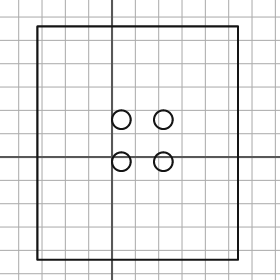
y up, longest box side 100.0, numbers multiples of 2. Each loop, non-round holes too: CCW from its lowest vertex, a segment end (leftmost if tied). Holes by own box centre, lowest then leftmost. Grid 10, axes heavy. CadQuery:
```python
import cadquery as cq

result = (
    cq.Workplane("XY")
    .moveTo(-32.0, -44.0)
    .lineTo(54.0, -44.0)
    .lineTo(54.0, 56.0)
    .lineTo(-32.0, 56.0)
    .close()
    .moveTo(4.0, -2.0)
    .circle(4.0)
    .moveTo(22.0, -2.0)
    .circle(4.0)
    .moveTo(4.0, 16.0)
    .circle(4.0)
    .moveTo(22.0, 16.0)
    .circle(4.0)
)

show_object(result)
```